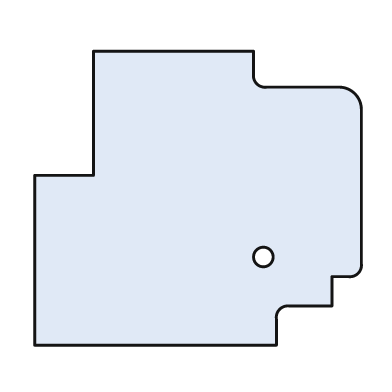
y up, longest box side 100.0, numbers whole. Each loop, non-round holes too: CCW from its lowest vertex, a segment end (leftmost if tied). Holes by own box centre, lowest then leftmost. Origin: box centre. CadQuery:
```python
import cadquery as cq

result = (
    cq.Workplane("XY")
    .moveTo(-50.0, -45.0)
    .lineTo(24.0, -45.0)
    .lineTo(24.0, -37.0)
    .threePointArc((25.0, -34.0), (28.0, -33.0))
    .lineTo(41.0, -33.0)
    .lineTo(41.0, -24.0)
    .lineTo(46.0, -24.0)
    .threePointArc((49.0, -23.0), (50.0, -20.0))
    .lineTo(50.0, 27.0)
    .threePointArc((48.0, 32.0), (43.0, 34.0))
    .lineTo(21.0, 34.0)
    .threePointArc((18.0, 35.0), (17.0, 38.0))
    .lineTo(17.0, 45.0)
    .lineTo(-32.0, 45.0)
    .lineTo(-32.0, 7.0)
    .lineTo(-50.0, 7.0)
    .close()
    .moveTo(20.0, -18.0)
    .circle(3.0)
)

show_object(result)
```